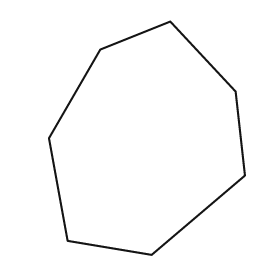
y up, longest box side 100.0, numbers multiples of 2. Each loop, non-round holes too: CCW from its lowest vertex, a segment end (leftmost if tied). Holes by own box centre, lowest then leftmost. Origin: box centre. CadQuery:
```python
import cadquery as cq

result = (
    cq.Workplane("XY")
    .moveTo(2.0, -50.0)
    .lineTo(42.0, -16.0)
    .lineTo(38.0, 20.0)
    .lineTo(10.0, 50.0)
    .lineTo(-20.0, 38.0)
    .lineTo(-42.0, 0.0)
    .lineTo(-34.0, -44.0)
    .close()
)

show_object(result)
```